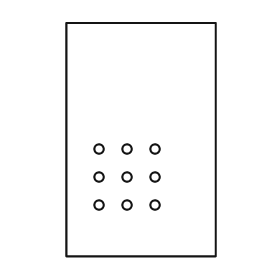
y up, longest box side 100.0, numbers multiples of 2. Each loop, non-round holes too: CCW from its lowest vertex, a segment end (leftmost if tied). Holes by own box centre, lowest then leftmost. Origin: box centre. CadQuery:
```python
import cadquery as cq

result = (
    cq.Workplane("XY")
    .moveTo(-32.0, -50.0)
    .lineTo(32.0, -50.0)
    .lineTo(32.0, 50.0)
    .lineTo(-32.0, 50.0)
    .close()
    .moveTo(-18.0, -28.0)
    .circle(2.0)
    .moveTo(-6.0, -28.0)
    .circle(2.0)
    .moveTo(6.0, -28.0)
    .circle(2.0)
    .moveTo(-18.0, -16.0)
    .circle(2.0)
    .moveTo(-6.0, -16.0)
    .circle(2.0)
    .moveTo(6.0, -16.0)
    .circle(2.0)
    .moveTo(-18.0, -4.0)
    .circle(2.0)
    .moveTo(-6.0, -4.0)
    .circle(2.0)
    .moveTo(6.0, -4.0)
    .circle(2.0)
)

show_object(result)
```